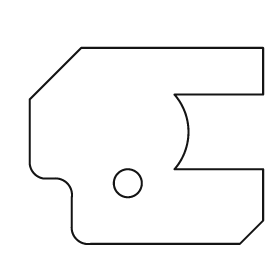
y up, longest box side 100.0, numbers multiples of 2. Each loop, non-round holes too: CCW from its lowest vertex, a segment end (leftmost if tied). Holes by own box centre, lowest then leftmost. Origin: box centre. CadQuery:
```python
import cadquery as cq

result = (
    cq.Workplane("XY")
    .moveTo(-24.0, -42.0)
    .lineTo(40.0, -42.0)
    .lineTo(50.0, -32.0)
    .lineTo(50.0, -10.0)
    .lineTo(12.0, -10.0)
    .threePointArc((18.0, 6.0), (12.0, 22.0))
    .lineTo(50.0, 22.0)
    .lineTo(50.0, 42.0)
    .lineTo(-28.0, 42.0)
    .lineTo(-50.0, 20.0)
    .lineTo(-50.0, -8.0)
    .threePointArc((-48.0, -12.0), (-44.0, -14.0))
    .lineTo(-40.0, -14.0)
    .threePointArc((-34.0, -16.0), (-32.0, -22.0))
    .lineTo(-32.0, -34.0)
    .threePointArc((-30.0, -40.0), (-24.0, -42.0))
    .close()
    .moveTo(-8.0, -16.0)
    .circle(6.0)
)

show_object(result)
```